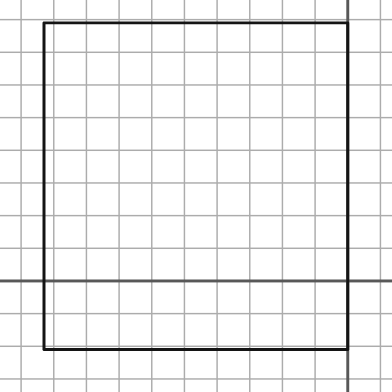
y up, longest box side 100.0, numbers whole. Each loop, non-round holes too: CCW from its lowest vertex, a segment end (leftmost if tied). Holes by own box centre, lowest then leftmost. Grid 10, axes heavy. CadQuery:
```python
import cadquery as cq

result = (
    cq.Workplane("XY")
    .moveTo(-93.0, -21.0)
    .lineTo(0.0, -21.0)
    .lineTo(0.0, 79.0)
    .lineTo(-93.0, 79.0)
    .close()
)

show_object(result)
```